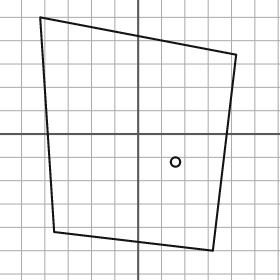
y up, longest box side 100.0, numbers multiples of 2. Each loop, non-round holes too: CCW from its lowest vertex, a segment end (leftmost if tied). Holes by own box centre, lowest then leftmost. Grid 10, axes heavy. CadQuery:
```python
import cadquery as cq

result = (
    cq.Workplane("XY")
    .moveTo(32.0, -50.0)
    .lineTo(42.0, 34.0)
    .lineTo(-42.0, 50.0)
    .lineTo(-36.0, -42.0)
    .close()
    .moveTo(16.0, -12.0)
    .circle(2.0)
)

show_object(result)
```